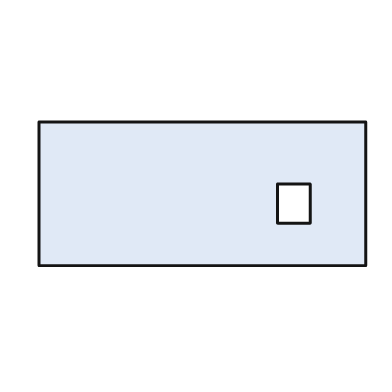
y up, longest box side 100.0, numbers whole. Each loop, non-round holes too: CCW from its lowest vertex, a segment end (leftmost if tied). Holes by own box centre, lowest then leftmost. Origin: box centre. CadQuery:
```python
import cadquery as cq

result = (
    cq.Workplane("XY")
    .moveTo(-50.0, -22.0)
    .lineTo(50.0, -22.0)
    .lineTo(50.0, 22.0)
    .lineTo(-50.0, 22.0)
    .close()
    .moveTo(23.0, -9.0)
    .lineTo(33.0, -9.0)
    .lineTo(33.0, 3.0)
    .lineTo(23.0, 3.0)
    .close()
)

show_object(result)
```